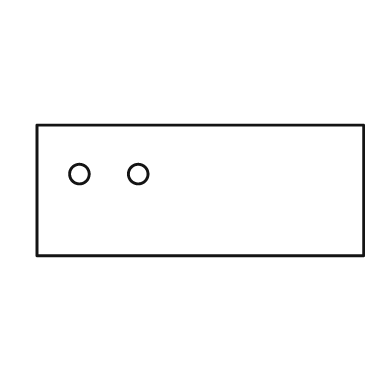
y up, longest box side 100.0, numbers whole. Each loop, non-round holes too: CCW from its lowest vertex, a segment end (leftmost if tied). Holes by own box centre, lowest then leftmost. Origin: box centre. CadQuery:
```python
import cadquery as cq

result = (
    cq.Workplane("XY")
    .moveTo(-50.0, -20.0)
    .lineTo(50.0, -20.0)
    .lineTo(50.0, 20.0)
    .lineTo(-50.0, 20.0)
    .close()
    .moveTo(-37.0, 5.0)
    .circle(3.0)
    .moveTo(-19.0, 5.0)
    .circle(3.0)
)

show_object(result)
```